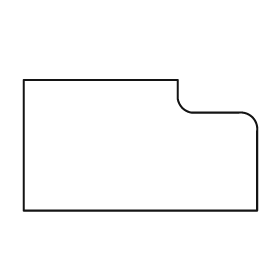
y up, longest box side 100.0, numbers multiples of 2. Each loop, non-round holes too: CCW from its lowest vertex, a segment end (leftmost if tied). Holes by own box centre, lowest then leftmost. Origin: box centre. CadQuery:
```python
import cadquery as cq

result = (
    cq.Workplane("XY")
    .moveTo(-50.0, -28.0)
    .lineTo(50.0, -28.0)
    .lineTo(50.0, 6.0)
    .threePointArc((48.0, 12.0), (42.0, 14.0))
    .lineTo(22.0, 14.0)
    .threePointArc((18.0, 16.0), (16.0, 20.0))
    .lineTo(16.0, 28.0)
    .lineTo(-50.0, 28.0)
    .close()
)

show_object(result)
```